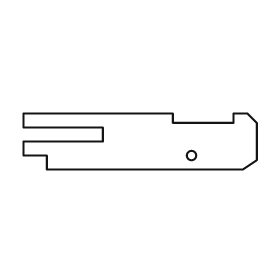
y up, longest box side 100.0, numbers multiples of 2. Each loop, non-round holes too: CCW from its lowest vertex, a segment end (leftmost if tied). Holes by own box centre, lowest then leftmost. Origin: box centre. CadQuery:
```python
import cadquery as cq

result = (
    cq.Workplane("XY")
    .moveTo(-40.0, -12.0)
    .lineTo(44.0, -12.0)
    .lineTo(50.0, -8.0)
    .lineTo(50.0, 8.0)
    .lineTo(46.0, 12.0)
    .lineTo(40.0, 12.0)
    .lineTo(40.0, 8.0)
    .lineTo(14.0, 8.0)
    .lineTo(14.0, 12.0)
    .lineTo(-50.0, 12.0)
    .lineTo(-50.0, 6.0)
    .lineTo(-16.0, 6.0)
    .lineTo(-16.0, 0.0)
    .lineTo(-50.0, 0.0)
    .lineTo(-50.0, -6.0)
    .lineTo(-40.0, -6.0)
    .close()
    .moveTo(22.0, -6.0)
    .circle(2.0)
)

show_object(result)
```